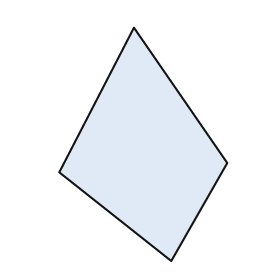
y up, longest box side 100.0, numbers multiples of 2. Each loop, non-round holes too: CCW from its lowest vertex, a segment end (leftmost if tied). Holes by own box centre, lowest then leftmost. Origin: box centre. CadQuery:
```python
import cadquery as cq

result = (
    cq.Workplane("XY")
    .moveTo(12.0, -50.0)
    .lineTo(36.0, -8.0)
    .lineTo(-4.0, 50.0)
    .lineTo(-36.0, -12.0)
    .close()
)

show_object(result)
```